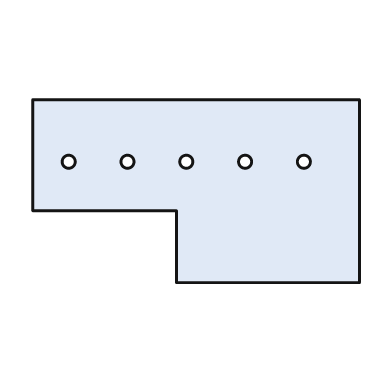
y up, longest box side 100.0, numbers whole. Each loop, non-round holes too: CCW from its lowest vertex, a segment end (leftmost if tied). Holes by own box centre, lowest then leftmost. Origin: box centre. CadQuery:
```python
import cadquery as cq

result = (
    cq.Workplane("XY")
    .moveTo(-6.0, -28.0)
    .lineTo(50.0, -28.0)
    .lineTo(50.0, 28.0)
    .lineTo(-50.0, 28.0)
    .lineTo(-50.0, -6.0)
    .lineTo(-6.0, -6.0)
    .close()
    .moveTo(-39.0, 9.0)
    .circle(2.0)
    .moveTo(-21.0, 9.0)
    .circle(2.0)
    .moveTo(-3.0, 9.0)
    .circle(2.0)
    .moveTo(15.0, 9.0)
    .circle(2.0)
    .moveTo(33.0, 9.0)
    .circle(2.0)
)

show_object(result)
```